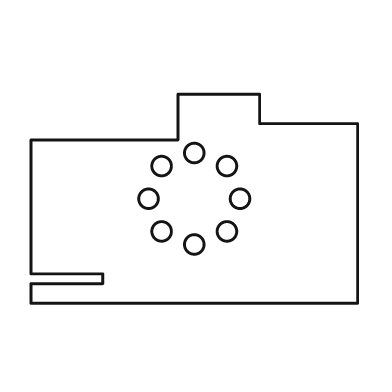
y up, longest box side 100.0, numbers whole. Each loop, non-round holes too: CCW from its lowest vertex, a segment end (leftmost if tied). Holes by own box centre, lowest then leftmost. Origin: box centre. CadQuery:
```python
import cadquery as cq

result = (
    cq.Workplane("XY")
    .moveTo(-50.0, -32.0)
    .lineTo(50.0, -32.0)
    .lineTo(50.0, 23.0)
    .lineTo(20.0, 23.0)
    .lineTo(20.0, 32.0)
    .lineTo(-5.0, 32.0)
    .lineTo(-5.0, 18.0)
    .lineTo(-50.0, 18.0)
    .lineTo(-50.0, -23.0)
    .lineTo(-28.0, -23.0)
    .lineTo(-28.0, -26.0)
    .lineTo(-50.0, -26.0)
    .close()
    .moveTo(0.0, -14.0)
    .circle(3.0)
    .moveTo(-10.0, -10.0)
    .circle(3.0)
    .moveTo(10.0, -10.0)
    .circle(3.0)
    .moveTo(-14.0, 0.0)
    .circle(3.0)
    .moveTo(14.0, 0.0)
    .circle(3.0)
    .moveTo(-10.0, 10.0)
    .circle(3.0)
    .moveTo(10.0, 10.0)
    .circle(3.0)
    .moveTo(0.0, 14.0)
    .circle(3.0)
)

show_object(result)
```